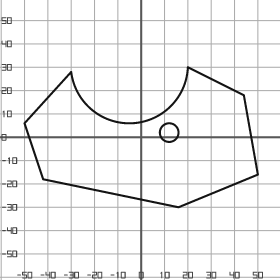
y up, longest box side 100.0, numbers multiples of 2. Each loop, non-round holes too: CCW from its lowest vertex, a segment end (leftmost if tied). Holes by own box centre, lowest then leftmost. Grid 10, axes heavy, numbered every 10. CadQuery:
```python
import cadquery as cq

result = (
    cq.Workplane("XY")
    .moveTo(16.0, -30.0)
    .lineTo(50.0, -16.0)
    .lineTo(44.0, 18.0)
    .lineTo(20.0, 30.0)
    .threePointArc((-4.0, 6.0), (-30.0, 28.0))
    .lineTo(-50.0, 6.0)
    .lineTo(-42.0, -18.0)
    .close()
    .moveTo(12.0, 2.0)
    .circle(4.0)
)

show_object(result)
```